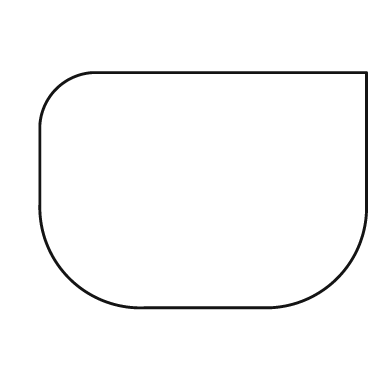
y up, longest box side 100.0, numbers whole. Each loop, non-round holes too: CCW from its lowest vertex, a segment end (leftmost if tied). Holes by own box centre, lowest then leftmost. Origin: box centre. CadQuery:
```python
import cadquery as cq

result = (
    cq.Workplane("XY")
    .moveTo(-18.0, -36.0)
    .lineTo(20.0, -36.0)
    .threePointArc((41.0, -27.0), (50.0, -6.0))
    .lineTo(50.0, 36.0)
    .lineTo(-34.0, 36.0)
    .threePointArc((-45.0, 31.0), (-50.0, 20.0))
    .lineTo(-50.0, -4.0)
    .threePointArc((-41.0, -27.0), (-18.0, -36.0))
    .close()
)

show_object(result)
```